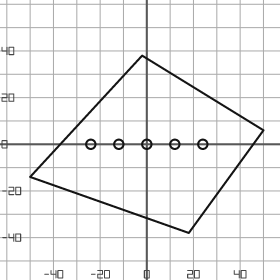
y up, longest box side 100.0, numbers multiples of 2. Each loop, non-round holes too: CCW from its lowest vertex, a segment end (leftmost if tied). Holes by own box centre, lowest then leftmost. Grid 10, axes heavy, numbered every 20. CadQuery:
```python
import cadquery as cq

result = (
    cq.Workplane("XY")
    .moveTo(18.0, -38.0)
    .lineTo(50.0, 6.0)
    .lineTo(-2.0, 38.0)
    .lineTo(-50.0, -14.0)
    .close()
    .moveTo(-24.0, 0.0)
    .circle(2.0)
    .moveTo(-12.0, 0.0)
    .circle(2.0)
    .moveTo(0.0, 0.0)
    .circle(2.0)
    .moveTo(12.0, 0.0)
    .circle(2.0)
    .moveTo(24.0, 0.0)
    .circle(2.0)
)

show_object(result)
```